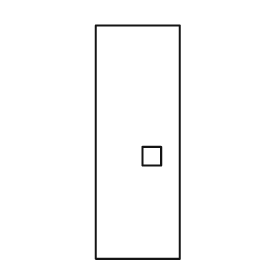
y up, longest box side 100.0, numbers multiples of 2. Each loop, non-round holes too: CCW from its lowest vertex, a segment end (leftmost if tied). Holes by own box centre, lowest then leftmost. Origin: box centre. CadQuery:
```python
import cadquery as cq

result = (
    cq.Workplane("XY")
    .moveTo(-18.0, -50.0)
    .lineTo(18.0, -50.0)
    .lineTo(18.0, 50.0)
    .lineTo(-18.0, 50.0)
    .close()
    .moveTo(2.0, -10.0)
    .lineTo(10.0, -10.0)
    .lineTo(10.0, -2.0)
    .lineTo(2.0, -2.0)
    .close()
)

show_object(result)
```